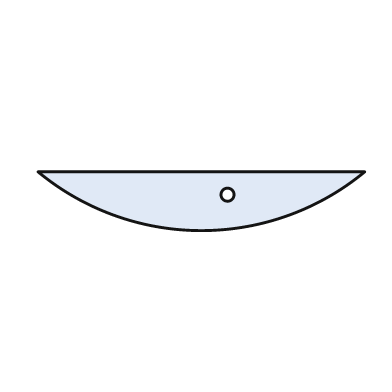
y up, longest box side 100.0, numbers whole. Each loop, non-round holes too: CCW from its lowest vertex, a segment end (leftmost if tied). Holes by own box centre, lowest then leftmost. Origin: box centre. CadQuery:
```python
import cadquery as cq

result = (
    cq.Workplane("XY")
    .moveTo(-50.0, 9.0)
    .threePointArc((0.0, -9.0), (50.0, 9.0))
    .close()
    .moveTo(8.0, 2.0)
    .circle(2.0)
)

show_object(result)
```